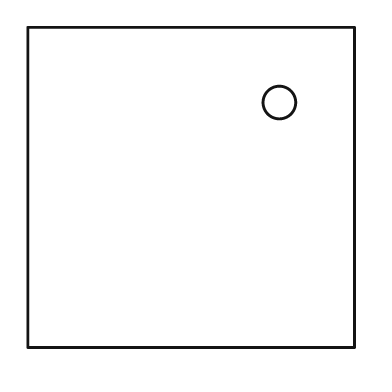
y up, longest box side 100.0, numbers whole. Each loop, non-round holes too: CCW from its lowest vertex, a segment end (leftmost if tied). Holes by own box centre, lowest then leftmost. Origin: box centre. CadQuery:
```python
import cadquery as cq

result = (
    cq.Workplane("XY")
    .moveTo(-50.0, -49.0)
    .lineTo(50.0, -49.0)
    .lineTo(50.0, 49.0)
    .lineTo(-50.0, 49.0)
    .close()
    .moveTo(27.0, 26.0)
    .circle(5.0)
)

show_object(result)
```